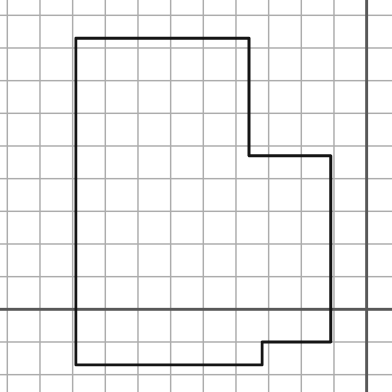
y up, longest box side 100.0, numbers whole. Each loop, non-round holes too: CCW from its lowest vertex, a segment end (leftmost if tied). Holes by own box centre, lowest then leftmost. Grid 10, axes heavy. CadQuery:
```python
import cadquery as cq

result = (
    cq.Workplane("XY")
    .moveTo(-89.0, -17.0)
    .lineTo(-32.0, -17.0)
    .lineTo(-32.0, -10.0)
    .lineTo(-11.0, -10.0)
    .lineTo(-11.0, 47.0)
    .lineTo(-36.0, 47.0)
    .lineTo(-36.0, 83.0)
    .lineTo(-89.0, 83.0)
    .close()
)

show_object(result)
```